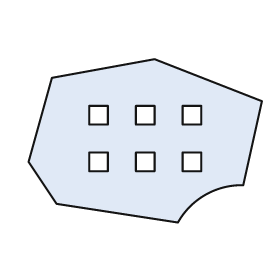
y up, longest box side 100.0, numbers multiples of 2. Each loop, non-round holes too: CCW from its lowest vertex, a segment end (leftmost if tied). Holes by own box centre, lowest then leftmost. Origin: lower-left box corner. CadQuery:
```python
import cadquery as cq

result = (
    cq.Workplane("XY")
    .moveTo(64.0, 0.0)
    .threePointArc((76.0, 12.0), (92.0, 16.0))
    .lineTo(100.0, 52.0)
    .lineTo(54.0, 70.0)
    .lineTo(10.0, 62.0)
    .lineTo(0.0, 26.0)
    .lineTo(12.0, 8.0)
    .close()
    .moveTo(26.0, 22.0)
    .lineTo(34.0, 22.0)
    .lineTo(34.0, 30.0)
    .lineTo(26.0, 30.0)
    .close()
    .moveTo(46.0, 22.0)
    .lineTo(54.0, 22.0)
    .lineTo(54.0, 30.0)
    .lineTo(46.0, 30.0)
    .close()
    .moveTo(66.0, 22.0)
    .lineTo(74.0, 22.0)
    .lineTo(74.0, 30.0)
    .lineTo(66.0, 30.0)
    .close()
    .moveTo(26.0, 42.0)
    .lineTo(34.0, 42.0)
    .lineTo(34.0, 50.0)
    .lineTo(26.0, 50.0)
    .close()
    .moveTo(46.0, 42.0)
    .lineTo(54.0, 42.0)
    .lineTo(54.0, 50.0)
    .lineTo(46.0, 50.0)
    .close()
    .moveTo(66.0, 42.0)
    .lineTo(74.0, 42.0)
    .lineTo(74.0, 50.0)
    .lineTo(66.0, 50.0)
    .close()
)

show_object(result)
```